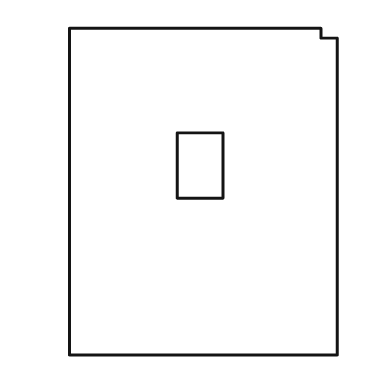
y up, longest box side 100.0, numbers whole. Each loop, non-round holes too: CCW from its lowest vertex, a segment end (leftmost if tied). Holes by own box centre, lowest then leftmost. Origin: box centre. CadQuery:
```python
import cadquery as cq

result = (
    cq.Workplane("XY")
    .moveTo(-41.0, -50.0)
    .lineTo(41.0, -50.0)
    .lineTo(41.0, 47.0)
    .lineTo(36.0, 47.0)
    .lineTo(36.0, 50.0)
    .lineTo(-41.0, 50.0)
    .close()
    .moveTo(-8.0, -2.0)
    .lineTo(6.0, -2.0)
    .lineTo(6.0, 18.0)
    .lineTo(-8.0, 18.0)
    .close()
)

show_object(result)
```